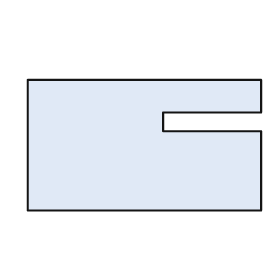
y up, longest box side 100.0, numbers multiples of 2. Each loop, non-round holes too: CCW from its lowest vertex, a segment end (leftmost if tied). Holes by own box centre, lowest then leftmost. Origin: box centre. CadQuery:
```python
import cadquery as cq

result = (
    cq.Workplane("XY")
    .moveTo(-50.0, -28.0)
    .lineTo(50.0, -28.0)
    .lineTo(50.0, 6.0)
    .lineTo(8.0, 6.0)
    .lineTo(8.0, 14.0)
    .lineTo(50.0, 14.0)
    .lineTo(50.0, 28.0)
    .lineTo(-50.0, 28.0)
    .close()
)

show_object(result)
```